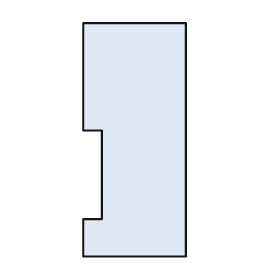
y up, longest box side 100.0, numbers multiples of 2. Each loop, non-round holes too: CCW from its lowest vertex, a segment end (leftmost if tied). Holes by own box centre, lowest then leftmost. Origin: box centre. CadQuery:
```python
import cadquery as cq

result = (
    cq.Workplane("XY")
    .moveTo(-22.0, -50.0)
    .lineTo(22.0, -50.0)
    .lineTo(22.0, 50.0)
    .lineTo(-22.0, 50.0)
    .lineTo(-22.0, 4.0)
    .lineTo(-14.0, 4.0)
    .lineTo(-14.0, -34.0)
    .lineTo(-22.0, -34.0)
    .close()
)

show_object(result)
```